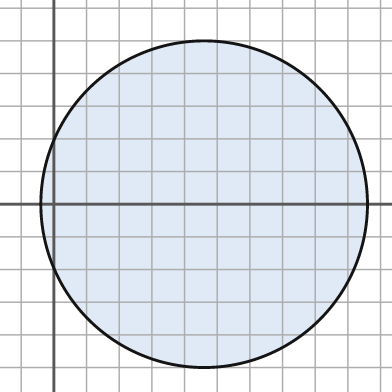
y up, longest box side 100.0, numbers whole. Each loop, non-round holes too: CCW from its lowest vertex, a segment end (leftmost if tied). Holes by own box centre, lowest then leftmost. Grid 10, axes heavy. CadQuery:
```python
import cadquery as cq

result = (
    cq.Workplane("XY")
    .moveTo(46.0, 0.0)
    .circle(50.0)
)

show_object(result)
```